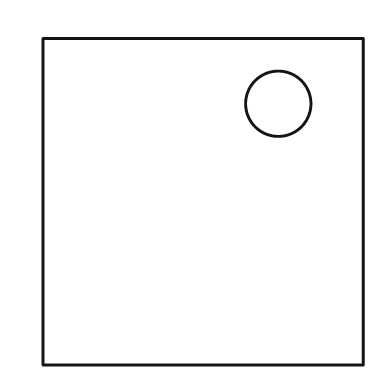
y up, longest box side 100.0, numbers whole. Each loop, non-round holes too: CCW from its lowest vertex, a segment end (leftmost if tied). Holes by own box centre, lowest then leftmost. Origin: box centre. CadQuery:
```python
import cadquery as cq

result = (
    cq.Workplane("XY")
    .moveTo(-49.0, -50.0)
    .lineTo(49.0, -50.0)
    .lineTo(49.0, 50.0)
    .lineTo(-49.0, 50.0)
    .close()
    .moveTo(23.0, 30.0)
    .circle(10.0)
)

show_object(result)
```